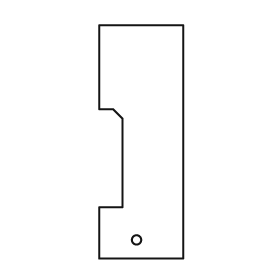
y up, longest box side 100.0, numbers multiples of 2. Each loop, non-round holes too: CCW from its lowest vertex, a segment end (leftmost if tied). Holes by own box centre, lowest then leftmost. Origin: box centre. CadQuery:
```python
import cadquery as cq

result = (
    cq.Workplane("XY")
    .moveTo(-18.0, -50.0)
    .lineTo(18.0, -50.0)
    .lineTo(18.0, 50.0)
    .lineTo(-18.0, 50.0)
    .lineTo(-18.0, 14.0)
    .lineTo(-12.0, 14.0)
    .lineTo(-8.0, 10.0)
    .lineTo(-8.0, -28.0)
    .lineTo(-18.0, -28.0)
    .close()
    .moveTo(-2.0, -42.0)
    .circle(2.0)
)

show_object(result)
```